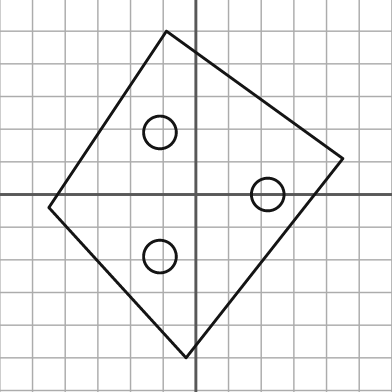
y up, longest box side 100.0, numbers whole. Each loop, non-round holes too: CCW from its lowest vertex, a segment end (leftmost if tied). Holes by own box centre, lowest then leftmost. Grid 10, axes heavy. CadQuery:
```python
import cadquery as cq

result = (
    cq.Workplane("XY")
    .moveTo(-3.0, -50.0)
    .lineTo(45.0, 11.0)
    .lineTo(-9.0, 50.0)
    .lineTo(-45.0, -4.0)
    .close()
    .moveTo(-11.0, -19.0)
    .circle(5.0)
    .moveTo(22.0, 0.0)
    .circle(5.0)
    .moveTo(-11.0, 19.0)
    .circle(5.0)
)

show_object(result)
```